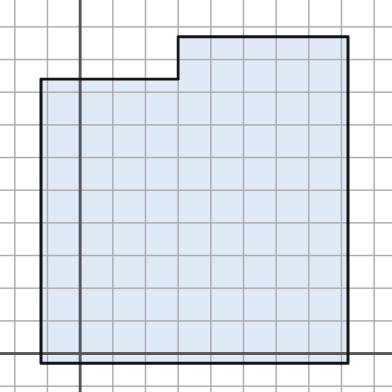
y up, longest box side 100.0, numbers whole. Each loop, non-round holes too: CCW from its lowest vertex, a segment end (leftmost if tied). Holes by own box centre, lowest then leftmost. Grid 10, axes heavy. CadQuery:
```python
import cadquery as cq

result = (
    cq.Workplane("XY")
    .moveTo(-12.0, -3.0)
    .lineTo(82.0, -3.0)
    .lineTo(82.0, 97.0)
    .lineTo(30.0, 97.0)
    .lineTo(30.0, 84.0)
    .lineTo(-12.0, 84.0)
    .close()
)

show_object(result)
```